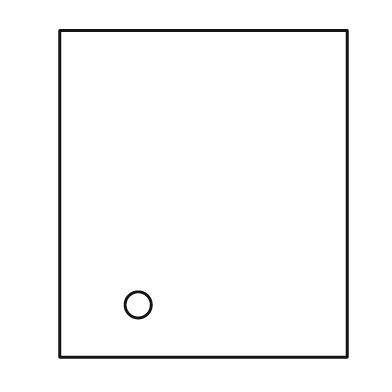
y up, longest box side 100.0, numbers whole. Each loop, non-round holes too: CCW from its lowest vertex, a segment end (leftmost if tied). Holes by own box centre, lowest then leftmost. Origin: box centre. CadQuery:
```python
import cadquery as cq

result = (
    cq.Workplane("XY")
    .moveTo(-44.0, -50.0)
    .lineTo(44.0, -50.0)
    .lineTo(44.0, 50.0)
    .lineTo(-44.0, 50.0)
    .close()
    .moveTo(-20.0, -34.0)
    .circle(4.0)
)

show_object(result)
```